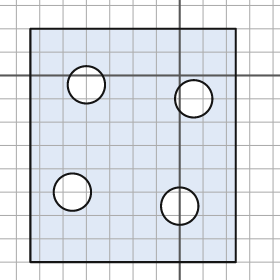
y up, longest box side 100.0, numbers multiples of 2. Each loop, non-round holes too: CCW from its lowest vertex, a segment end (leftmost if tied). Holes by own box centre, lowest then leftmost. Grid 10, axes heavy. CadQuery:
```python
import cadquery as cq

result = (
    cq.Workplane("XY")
    .moveTo(-64.0, -80.0)
    .lineTo(24.0, -80.0)
    .lineTo(24.0, 20.0)
    .lineTo(-64.0, 20.0)
    .close()
    .moveTo(0.0, -56.0)
    .circle(8.0)
    .moveTo(-46.0, -50.0)
    .circle(8.0)
    .moveTo(6.0, -10.0)
    .circle(8.0)
    .moveTo(-40.0, -4.0)
    .circle(8.0)
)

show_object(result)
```